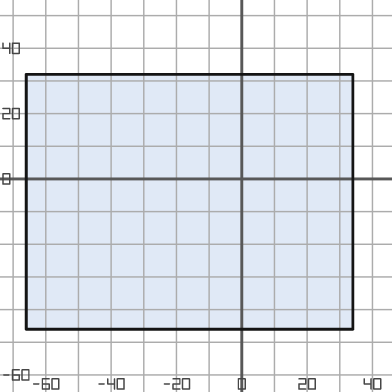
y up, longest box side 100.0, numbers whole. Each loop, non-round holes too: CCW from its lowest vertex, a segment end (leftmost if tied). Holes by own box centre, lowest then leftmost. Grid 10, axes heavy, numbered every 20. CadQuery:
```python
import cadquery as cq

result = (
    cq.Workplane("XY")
    .moveTo(-66.0, -46.0)
    .lineTo(34.0, -46.0)
    .lineTo(34.0, 32.0)
    .lineTo(-66.0, 32.0)
    .close()
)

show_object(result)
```